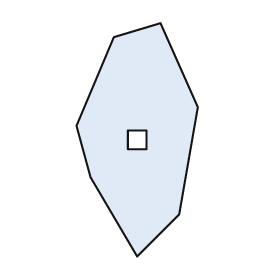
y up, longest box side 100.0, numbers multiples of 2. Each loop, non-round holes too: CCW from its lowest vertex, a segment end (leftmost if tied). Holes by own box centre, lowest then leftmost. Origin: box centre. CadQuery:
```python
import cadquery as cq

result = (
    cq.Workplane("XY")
    .moveTo(0.0, -50.0)
    .lineTo(18.0, -32.0)
    .lineTo(26.0, 14.0)
    .lineTo(10.0, 50.0)
    .lineTo(-10.0, 44.0)
    .lineTo(-26.0, 6.0)
    .lineTo(-20.0, -16.0)
    .close()
    .moveTo(-4.0, -4.0)
    .lineTo(4.0, -4.0)
    .lineTo(4.0, 4.0)
    .lineTo(-4.0, 4.0)
    .close()
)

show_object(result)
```